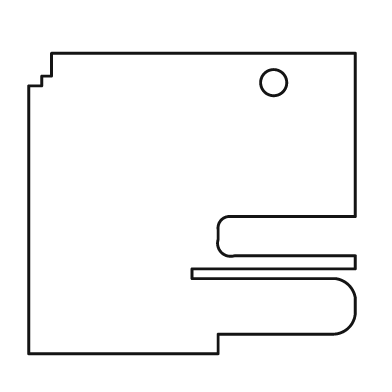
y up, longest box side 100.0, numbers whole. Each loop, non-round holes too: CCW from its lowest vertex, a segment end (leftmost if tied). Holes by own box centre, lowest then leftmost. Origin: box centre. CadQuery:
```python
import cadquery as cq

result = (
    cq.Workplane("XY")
    .moveTo(-50.0, -46.0)
    .lineTo(8.0, -46.0)
    .lineTo(8.0, -40.0)
    .lineTo(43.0, -40.0)
    .threePointArc((48.0, -38.0), (50.0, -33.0))
    .lineTo(50.0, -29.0)
    .threePointArc((48.0, -25.0), (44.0, -23.0))
    .lineTo(0.0, -23.0)
    .lineTo(0.0, -20.0)
    .lineTo(50.0, -20.0)
    .lineTo(50.0, -16.0)
    .lineTo(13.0, -16.0)
    .threePointArc((9.0, -15.0), (8.0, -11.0))
    .lineTo(8.0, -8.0)
    .threePointArc((9.0, -5.0), (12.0, -4.0))
    .lineTo(50.0, -4.0)
    .lineTo(50.0, 46.0)
    .lineTo(-43.0, 46.0)
    .lineTo(-43.0, 39.0)
    .lineTo(-46.0, 39.0)
    .lineTo(-46.0, 36.0)
    .lineTo(-50.0, 36.0)
    .close()
    .moveTo(25.0, 37.0)
    .circle(4.0)
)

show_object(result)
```